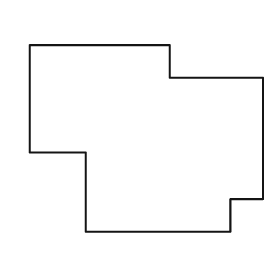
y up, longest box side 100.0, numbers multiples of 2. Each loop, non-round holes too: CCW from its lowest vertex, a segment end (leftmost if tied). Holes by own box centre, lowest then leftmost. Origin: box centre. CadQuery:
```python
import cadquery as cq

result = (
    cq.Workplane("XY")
    .moveTo(-26.0, -40.0)
    .lineTo(36.0, -40.0)
    .lineTo(36.0, -26.0)
    .lineTo(50.0, -26.0)
    .lineTo(50.0, 26.0)
    .lineTo(10.0, 26.0)
    .lineTo(10.0, 40.0)
    .lineTo(-50.0, 40.0)
    .lineTo(-50.0, -6.0)
    .lineTo(-26.0, -6.0)
    .close()
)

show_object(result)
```